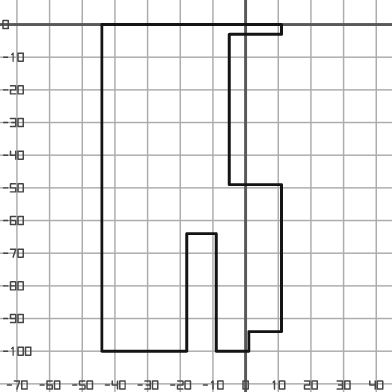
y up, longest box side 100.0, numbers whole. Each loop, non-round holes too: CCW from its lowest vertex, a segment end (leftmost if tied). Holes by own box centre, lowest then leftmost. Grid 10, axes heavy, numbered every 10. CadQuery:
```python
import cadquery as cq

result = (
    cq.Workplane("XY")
    .moveTo(-44.0, -100.0)
    .lineTo(-18.0, -100.0)
    .lineTo(-18.0, -64.0)
    .lineTo(-9.0, -64.0)
    .lineTo(-9.0, -100.0)
    .lineTo(1.0, -100.0)
    .lineTo(1.0, -94.0)
    .lineTo(11.0, -94.0)
    .lineTo(11.0, -49.0)
    .lineTo(-5.0, -49.0)
    .lineTo(-5.0, -3.0)
    .lineTo(11.0, -3.0)
    .lineTo(11.0, 0.0)
    .lineTo(-44.0, 0.0)
    .close()
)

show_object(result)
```